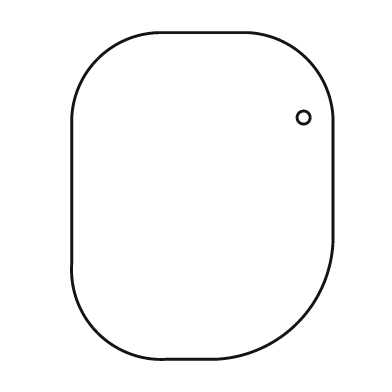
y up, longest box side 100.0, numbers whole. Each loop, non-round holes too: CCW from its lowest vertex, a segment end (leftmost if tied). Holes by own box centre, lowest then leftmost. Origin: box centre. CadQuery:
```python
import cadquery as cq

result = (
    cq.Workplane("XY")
    .moveTo(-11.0, -50.0)
    .lineTo(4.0, -50.0)
    .threePointArc((29.0, -39.0), (40.0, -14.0))
    .lineTo(40.0, 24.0)
    .threePointArc((32.0, 42.0), (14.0, 50.0))
    .lineTo(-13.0, 50.0)
    .threePointArc((-32.0, 42.0), (-40.0, 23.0))
    .lineTo(-40.0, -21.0)
    .threePointArc((-32.0, -42.0), (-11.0, -50.0))
    .close()
    .moveTo(31.0, 24.0)
    .circle(2.0)
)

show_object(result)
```